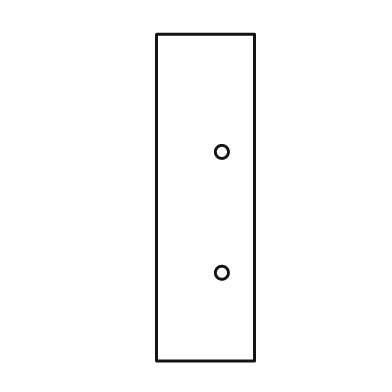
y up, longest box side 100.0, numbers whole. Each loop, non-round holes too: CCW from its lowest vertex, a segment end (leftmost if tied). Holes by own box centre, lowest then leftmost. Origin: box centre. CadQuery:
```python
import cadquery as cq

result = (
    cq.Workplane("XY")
    .moveTo(-15.0, -50.0)
    .lineTo(15.0, -50.0)
    .lineTo(15.0, 50.0)
    .lineTo(-15.0, 50.0)
    .close()
    .moveTo(5.0, -23.0)
    .circle(2.0)
    .moveTo(5.0, 14.0)
    .circle(2.0)
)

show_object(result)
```